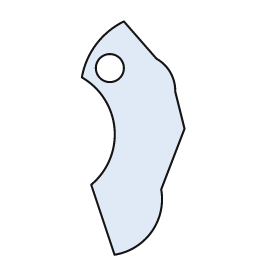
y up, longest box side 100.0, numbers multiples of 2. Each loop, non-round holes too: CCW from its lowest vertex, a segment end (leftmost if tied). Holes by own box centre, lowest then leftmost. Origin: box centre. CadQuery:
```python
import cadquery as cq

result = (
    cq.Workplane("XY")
    .moveTo(-8.0, -50.0)
    .threePointArc((8.0, -40.0), (12.0, -22.0))
    .lineTo(22.0, 4.0)
    .lineTo(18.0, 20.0)
    .threePointArc((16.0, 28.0), (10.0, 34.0))
    .lineTo(-4.0, 50.0)
    .threePointArc((-16.0, 40.0), (-22.0, 26.0))
    .threePointArc((-8.0, 4.0), (-18.0, -20.0))
    .close()
    .moveTo(-10.0, 30.0)
    .circle(6.0)
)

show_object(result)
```